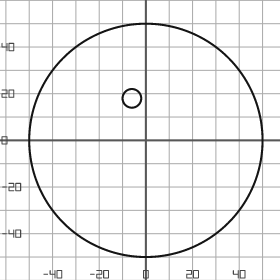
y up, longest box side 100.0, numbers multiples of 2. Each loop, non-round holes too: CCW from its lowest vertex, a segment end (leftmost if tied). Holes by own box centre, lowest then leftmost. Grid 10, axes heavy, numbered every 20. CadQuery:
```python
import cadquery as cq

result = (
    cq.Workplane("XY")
    .moveTo(0.0, 0.0)
    .circle(50.0)
    .moveTo(-6.0, 18.0)
    .circle(4.0)
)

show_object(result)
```